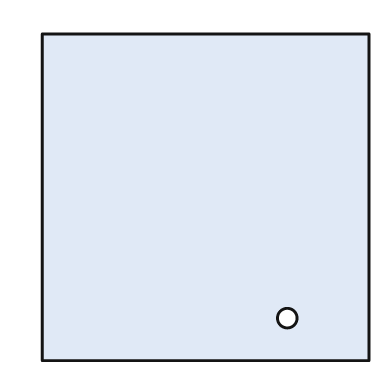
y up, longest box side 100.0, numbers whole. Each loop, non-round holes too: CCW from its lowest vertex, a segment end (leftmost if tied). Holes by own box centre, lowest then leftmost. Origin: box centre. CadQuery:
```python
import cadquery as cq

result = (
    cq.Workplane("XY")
    .moveTo(-50.0, -50.0)
    .lineTo(50.0, -50.0)
    .lineTo(50.0, 50.0)
    .lineTo(-50.0, 50.0)
    .close()
    .moveTo(25.0, -37.0)
    .circle(3.0)
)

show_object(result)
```